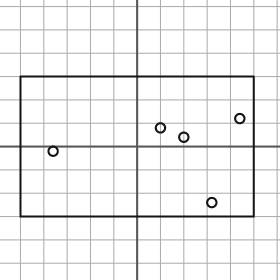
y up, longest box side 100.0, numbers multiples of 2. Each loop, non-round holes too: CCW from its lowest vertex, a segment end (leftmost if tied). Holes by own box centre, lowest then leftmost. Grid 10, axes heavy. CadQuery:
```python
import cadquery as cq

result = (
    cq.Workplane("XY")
    .moveTo(-50.0, -30.0)
    .lineTo(50.0, -30.0)
    .lineTo(50.0, 30.0)
    .lineTo(-50.0, 30.0)
    .close()
    .moveTo(32.0, -24.0)
    .circle(2.0)
    .moveTo(-36.0, -2.0)
    .circle(2.0)
    .moveTo(20.0, 4.0)
    .circle(2.0)
    .moveTo(10.0, 8.0)
    .circle(2.0)
    .moveTo(44.0, 12.0)
    .circle(2.0)
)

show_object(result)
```